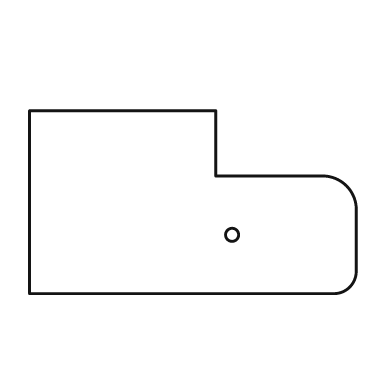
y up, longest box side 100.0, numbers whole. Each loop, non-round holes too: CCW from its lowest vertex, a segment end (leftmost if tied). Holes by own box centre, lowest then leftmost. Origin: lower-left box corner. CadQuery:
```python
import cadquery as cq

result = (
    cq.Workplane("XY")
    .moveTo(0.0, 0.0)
    .lineTo(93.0, 0.0)
    .threePointArc((98.0, 2.0), (100.0, 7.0))
    .lineTo(100.0, 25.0)
    .threePointArc((97.0, 33.0), (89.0, 36.0))
    .lineTo(57.0, 36.0)
    .lineTo(57.0, 56.0)
    .lineTo(0.0, 56.0)
    .close()
    .moveTo(62.0, 18.0)
    .circle(2.0)
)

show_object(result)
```